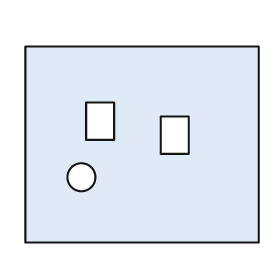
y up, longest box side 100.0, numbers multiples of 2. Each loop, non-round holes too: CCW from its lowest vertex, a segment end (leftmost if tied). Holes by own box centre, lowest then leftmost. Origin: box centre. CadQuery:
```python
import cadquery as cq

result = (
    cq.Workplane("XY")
    .moveTo(-50.0, -42.0)
    .lineTo(50.0, -42.0)
    .lineTo(50.0, 42.0)
    .lineTo(-50.0, 42.0)
    .close()
    .moveTo(-26.0, -14.0)
    .circle(6.0)
    .moveTo(8.0, -4.0)
    .lineTo(20.0, -4.0)
    .lineTo(20.0, 12.0)
    .lineTo(8.0, 12.0)
    .close()
    .moveTo(-24.0, 2.0)
    .lineTo(-12.0, 2.0)
    .lineTo(-12.0, 18.0)
    .lineTo(-24.0, 18.0)
    .close()
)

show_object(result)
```